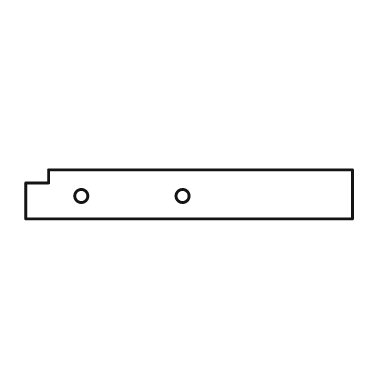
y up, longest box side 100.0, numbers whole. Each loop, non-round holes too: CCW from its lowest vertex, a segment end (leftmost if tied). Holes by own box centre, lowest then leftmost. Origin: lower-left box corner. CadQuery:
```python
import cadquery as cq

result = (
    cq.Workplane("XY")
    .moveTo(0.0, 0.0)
    .lineTo(100.0, 0.0)
    .lineTo(100.0, 15.0)
    .lineTo(7.0, 15.0)
    .lineTo(7.0, 11.0)
    .lineTo(0.0, 11.0)
    .close()
    .moveTo(17.0, 7.0)
    .circle(2.0)
    .moveTo(48.0, 7.0)
    .circle(2.0)
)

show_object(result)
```